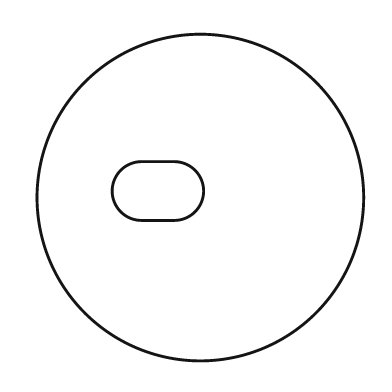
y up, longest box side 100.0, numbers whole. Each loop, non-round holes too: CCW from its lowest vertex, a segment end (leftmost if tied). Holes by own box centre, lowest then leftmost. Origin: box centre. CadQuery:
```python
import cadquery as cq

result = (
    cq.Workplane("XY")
    .moveTo(0.0, 0.0)
    .circle(50.0)
    .moveTo(-18.0, -7.0)
    .lineTo(-8.0, -7.0)
    .threePointArc((1.0, 2.0), (-8.0, 11.0))
    .lineTo(-18.0, 11.0)
    .threePointArc((-27.0, 2.0), (-18.0, -7.0))
    .close()
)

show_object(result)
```